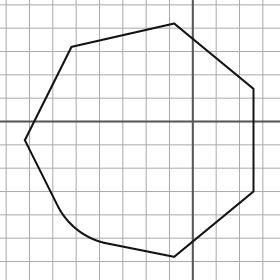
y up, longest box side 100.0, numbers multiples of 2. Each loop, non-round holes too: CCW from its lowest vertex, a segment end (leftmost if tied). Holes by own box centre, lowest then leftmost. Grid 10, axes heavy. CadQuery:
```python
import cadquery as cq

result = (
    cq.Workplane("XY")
    .moveTo(-8.0, -58.0)
    .lineTo(26.0, -30.0)
    .lineTo(26.0, 14.0)
    .lineTo(-8.0, 42.0)
    .lineTo(-52.0, 32.0)
    .lineTo(-72.0, -8.0)
    .lineTo(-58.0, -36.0)
    .threePointArc((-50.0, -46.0), (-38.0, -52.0))
    .close()
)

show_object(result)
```